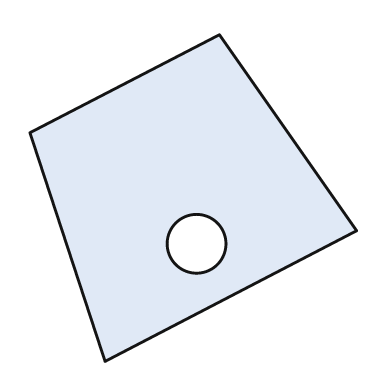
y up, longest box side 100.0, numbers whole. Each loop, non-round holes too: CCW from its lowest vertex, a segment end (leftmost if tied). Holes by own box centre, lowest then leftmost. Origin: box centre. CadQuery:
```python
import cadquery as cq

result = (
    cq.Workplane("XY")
    .moveTo(-27.0, -50.0)
    .lineTo(50.0, -10.0)
    .lineTo(8.0, 50.0)
    .lineTo(-50.0, 20.0)
    .close()
    .moveTo(1.0, -14.0)
    .circle(9.0)
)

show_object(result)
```